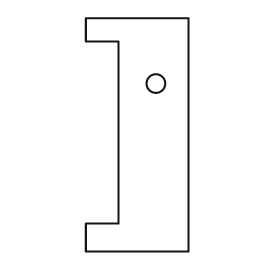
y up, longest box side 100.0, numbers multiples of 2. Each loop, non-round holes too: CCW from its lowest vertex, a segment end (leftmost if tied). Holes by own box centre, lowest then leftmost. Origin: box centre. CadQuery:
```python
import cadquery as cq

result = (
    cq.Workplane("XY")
    .moveTo(-22.0, -50.0)
    .lineTo(22.0, -50.0)
    .lineTo(22.0, 50.0)
    .lineTo(-22.0, 50.0)
    .lineTo(-22.0, 40.0)
    .lineTo(-8.0, 40.0)
    .lineTo(-8.0, -38.0)
    .lineTo(-22.0, -38.0)
    .close()
    .moveTo(8.0, 22.0)
    .circle(4.0)
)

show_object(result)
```